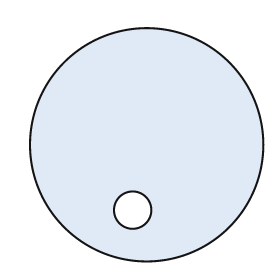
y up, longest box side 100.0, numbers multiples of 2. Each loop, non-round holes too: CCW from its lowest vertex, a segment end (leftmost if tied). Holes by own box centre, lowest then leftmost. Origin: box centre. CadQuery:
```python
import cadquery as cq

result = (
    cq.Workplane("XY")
    .moveTo(0.0, 0.0)
    .circle(50.0)
    .moveTo(-6.0, -28.0)
    .circle(8.0)
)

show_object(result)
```